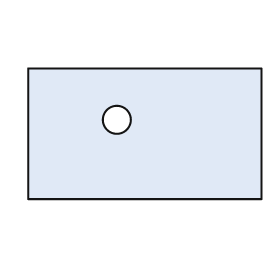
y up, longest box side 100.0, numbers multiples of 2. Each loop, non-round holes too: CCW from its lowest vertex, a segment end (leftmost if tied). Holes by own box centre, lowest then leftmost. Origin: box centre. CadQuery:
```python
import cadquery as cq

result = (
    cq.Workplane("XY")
    .moveTo(-50.0, -28.0)
    .lineTo(50.0, -28.0)
    .lineTo(50.0, 28.0)
    .lineTo(-50.0, 28.0)
    .close()
    .moveTo(-12.0, 6.0)
    .circle(6.0)
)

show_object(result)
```